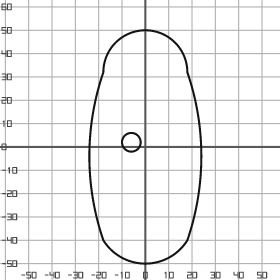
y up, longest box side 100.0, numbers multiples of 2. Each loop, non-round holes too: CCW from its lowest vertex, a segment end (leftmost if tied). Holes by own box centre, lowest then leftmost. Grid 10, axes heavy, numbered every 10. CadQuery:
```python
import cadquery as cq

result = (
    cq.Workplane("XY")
    .moveTo(-18.0, -40.0)
    .threePointArc((0.0, -50.0), (18.0, -40.0))
    .threePointArc((24.0, -4.0), (18.0, 32.0))
    .threePointArc((0.0, 50.0), (-18.0, 32.0))
    .threePointArc((-24.0, -4.0), (-18.0, -40.0))
    .close()
    .moveTo(-6.0, 2.0)
    .circle(4.0)
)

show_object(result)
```